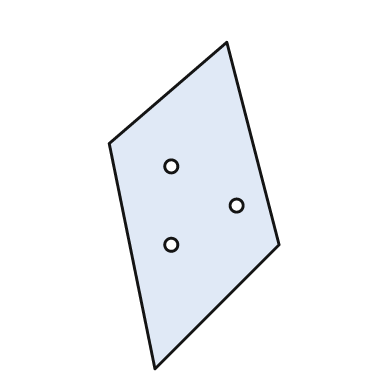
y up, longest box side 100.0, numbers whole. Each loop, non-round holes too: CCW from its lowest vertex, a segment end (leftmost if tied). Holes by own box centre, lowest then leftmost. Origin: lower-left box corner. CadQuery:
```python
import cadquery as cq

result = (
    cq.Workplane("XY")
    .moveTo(14.0, 0.0)
    .lineTo(52.0, 38.0)
    .lineTo(36.0, 100.0)
    .lineTo(0.0, 69.0)
    .close()
    .moveTo(19.0, 38.0)
    .circle(2.0)
    .moveTo(39.0, 50.0)
    .circle(2.0)
    .moveTo(19.0, 62.0)
    .circle(2.0)
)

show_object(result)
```